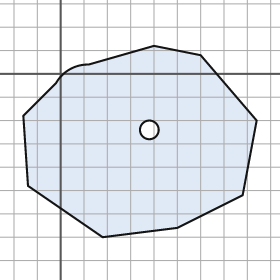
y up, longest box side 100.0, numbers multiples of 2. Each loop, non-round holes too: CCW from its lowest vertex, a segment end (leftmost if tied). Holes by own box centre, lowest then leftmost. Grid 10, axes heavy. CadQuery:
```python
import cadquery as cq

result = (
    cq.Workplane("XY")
    .moveTo(18.0, -70.0)
    .lineTo(50.0, -66.0)
    .lineTo(78.0, -52.0)
    .lineTo(84.0, -20.0)
    .lineTo(60.0, 8.0)
    .lineTo(40.0, 12.0)
    .lineTo(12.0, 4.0)
    .threePointArc((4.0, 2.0), (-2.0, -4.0))
    .lineTo(-16.0, -18.0)
    .lineTo(-14.0, -48.0)
    .close()
    .moveTo(38.0, -24.0)
    .circle(4.0)
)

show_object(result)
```